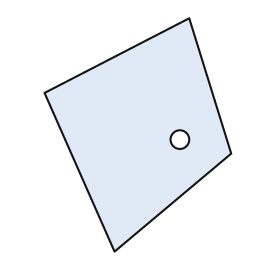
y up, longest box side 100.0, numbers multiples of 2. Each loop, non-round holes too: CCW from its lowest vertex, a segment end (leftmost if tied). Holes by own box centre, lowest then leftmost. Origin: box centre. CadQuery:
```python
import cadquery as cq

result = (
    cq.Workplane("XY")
    .moveTo(-10.0, -50.0)
    .lineTo(40.0, -8.0)
    .lineTo(22.0, 50.0)
    .lineTo(-40.0, 18.0)
    .close()
    .moveTo(18.0, -2.0)
    .circle(4.0)
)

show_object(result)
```